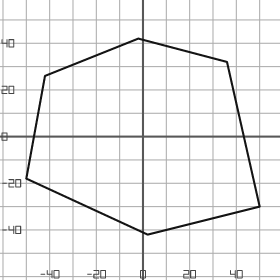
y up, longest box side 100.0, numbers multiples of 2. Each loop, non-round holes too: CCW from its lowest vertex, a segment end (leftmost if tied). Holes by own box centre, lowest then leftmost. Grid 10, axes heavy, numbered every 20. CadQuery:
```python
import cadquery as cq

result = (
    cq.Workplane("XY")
    .moveTo(2.0, -42.0)
    .lineTo(50.0, -30.0)
    .lineTo(36.0, 32.0)
    .lineTo(-2.0, 42.0)
    .lineTo(-42.0, 26.0)
    .lineTo(-50.0, -18.0)
    .close()
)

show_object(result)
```